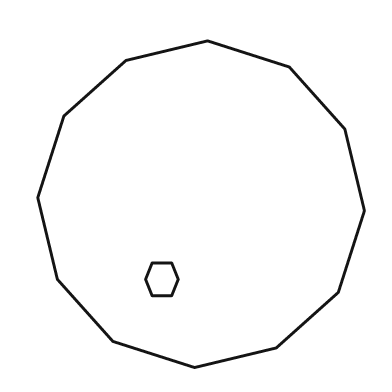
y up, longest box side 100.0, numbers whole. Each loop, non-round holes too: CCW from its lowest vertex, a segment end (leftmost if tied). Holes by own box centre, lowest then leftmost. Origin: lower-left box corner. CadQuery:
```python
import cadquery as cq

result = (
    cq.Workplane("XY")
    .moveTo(48.0, 0.0)
    .lineTo(73.0, 6.0)
    .lineTo(92.0, 23.0)
    .lineTo(100.0, 48.0)
    .lineTo(94.0, 73.0)
    .lineTo(77.0, 92.0)
    .lineTo(52.0, 100.0)
    .lineTo(27.0, 94.0)
    .lineTo(8.0, 77.0)
    .lineTo(0.0, 52.0)
    .lineTo(6.0, 27.0)
    .lineTo(23.0, 8.0)
    .close()
    .moveTo(35.0, 22.0)
    .lineTo(41.0, 22.0)
    .lineTo(43.0, 27.0)
    .lineTo(41.0, 32.0)
    .lineTo(35.0, 32.0)
    .lineTo(33.0, 27.0)
    .close()
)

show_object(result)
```